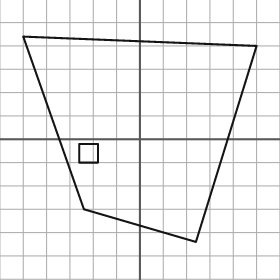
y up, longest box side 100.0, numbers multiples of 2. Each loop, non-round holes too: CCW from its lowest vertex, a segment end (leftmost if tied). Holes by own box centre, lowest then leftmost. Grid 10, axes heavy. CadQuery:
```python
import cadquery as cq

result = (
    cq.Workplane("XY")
    .moveTo(24.0, -44.0)
    .lineTo(50.0, 40.0)
    .lineTo(-50.0, 44.0)
    .lineTo(-24.0, -30.0)
    .close()
    .moveTo(-26.0, -10.0)
    .lineTo(-18.0, -10.0)
    .lineTo(-18.0, -2.0)
    .lineTo(-26.0, -2.0)
    .close()
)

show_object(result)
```